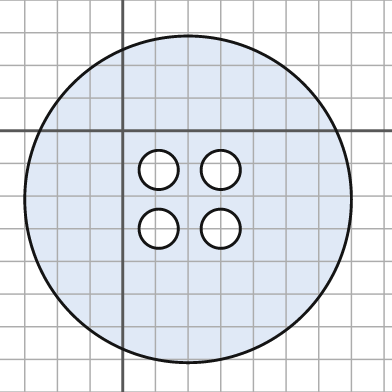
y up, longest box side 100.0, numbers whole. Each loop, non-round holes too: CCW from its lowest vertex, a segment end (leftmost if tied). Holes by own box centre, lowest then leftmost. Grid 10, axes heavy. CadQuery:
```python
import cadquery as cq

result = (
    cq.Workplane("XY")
    .moveTo(20.0, -21.0)
    .circle(50.0)
    .moveTo(11.0, -30.0)
    .circle(6.0)
    .moveTo(30.0, -30.0)
    .circle(6.0)
    .moveTo(11.0, -12.0)
    .circle(6.0)
    .moveTo(30.0, -12.0)
    .circle(6.0)
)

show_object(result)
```